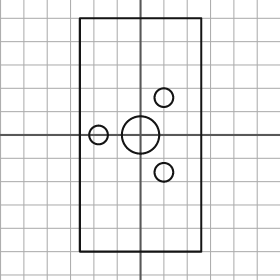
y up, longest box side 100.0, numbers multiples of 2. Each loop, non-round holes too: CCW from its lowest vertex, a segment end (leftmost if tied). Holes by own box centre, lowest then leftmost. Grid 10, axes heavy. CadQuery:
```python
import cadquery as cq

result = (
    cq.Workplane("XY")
    .moveTo(-26.0, -50.0)
    .lineTo(26.0, -50.0)
    .lineTo(26.0, 50.0)
    .lineTo(-26.0, 50.0)
    .close()
    .moveTo(10.0, -16.0)
    .circle(4.0)
    .moveTo(-18.0, 0.0)
    .circle(4.0)
    .moveTo(0.0, 0.0)
    .circle(8.0)
    .moveTo(10.0, 16.0)
    .circle(4.0)
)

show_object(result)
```